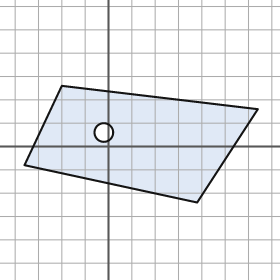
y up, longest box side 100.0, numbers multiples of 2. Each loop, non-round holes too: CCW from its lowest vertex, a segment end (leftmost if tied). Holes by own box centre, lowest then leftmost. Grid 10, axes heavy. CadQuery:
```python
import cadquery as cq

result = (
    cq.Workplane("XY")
    .moveTo(38.0, -24.0)
    .lineTo(64.0, 16.0)
    .lineTo(-20.0, 26.0)
    .lineTo(-36.0, -8.0)
    .close()
    .moveTo(-2.0, 6.0)
    .circle(4.0)
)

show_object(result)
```